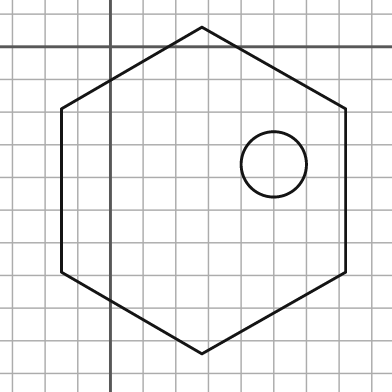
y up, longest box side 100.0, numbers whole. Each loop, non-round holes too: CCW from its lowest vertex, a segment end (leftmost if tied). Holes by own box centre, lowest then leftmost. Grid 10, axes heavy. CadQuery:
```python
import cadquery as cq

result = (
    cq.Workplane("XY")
    .moveTo(28.0, -94.0)
    .lineTo(72.0, -69.0)
    .lineTo(72.0, -19.0)
    .lineTo(28.0, 6.0)
    .lineTo(-15.0, -19.0)
    .lineTo(-15.0, -69.0)
    .close()
    .moveTo(50.0, -36.0)
    .circle(10.0)
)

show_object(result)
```